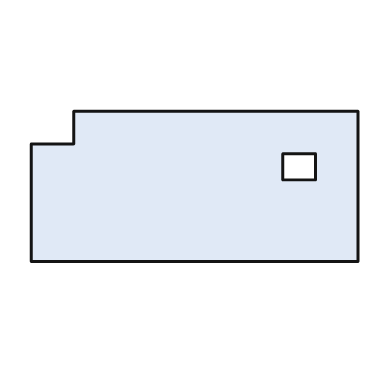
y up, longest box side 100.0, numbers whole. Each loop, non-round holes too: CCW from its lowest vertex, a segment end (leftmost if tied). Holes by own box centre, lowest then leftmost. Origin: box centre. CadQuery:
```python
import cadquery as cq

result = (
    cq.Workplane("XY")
    .moveTo(-50.0, -23.0)
    .lineTo(50.0, -23.0)
    .lineTo(50.0, 23.0)
    .lineTo(-37.0, 23.0)
    .lineTo(-37.0, 13.0)
    .lineTo(-50.0, 13.0)
    .close()
    .moveTo(27.0, 2.0)
    .lineTo(37.0, 2.0)
    .lineTo(37.0, 10.0)
    .lineTo(27.0, 10.0)
    .close()
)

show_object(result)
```